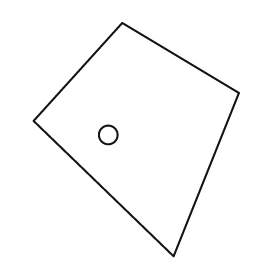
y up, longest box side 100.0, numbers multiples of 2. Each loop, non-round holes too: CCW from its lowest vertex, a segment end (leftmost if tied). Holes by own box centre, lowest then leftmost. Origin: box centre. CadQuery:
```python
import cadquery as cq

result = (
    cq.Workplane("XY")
    .moveTo(16.0, -50.0)
    .lineTo(44.0, 20.0)
    .lineTo(-6.0, 50.0)
    .lineTo(-44.0, 8.0)
    .close()
    .moveTo(-12.0, 2.0)
    .circle(4.0)
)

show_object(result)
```